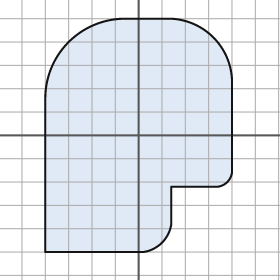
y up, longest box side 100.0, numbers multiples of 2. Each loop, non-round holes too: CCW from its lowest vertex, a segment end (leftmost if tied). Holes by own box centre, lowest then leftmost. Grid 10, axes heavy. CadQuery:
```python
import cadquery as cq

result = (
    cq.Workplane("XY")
    .moveTo(-40.0, -50.0)
    .lineTo(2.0, -50.0)
    .threePointArc((10.0, -46.0), (14.0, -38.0))
    .lineTo(14.0, -22.0)
    .lineTo(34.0, -22.0)
    .threePointArc((38.0, -20.0), (40.0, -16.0))
    .lineTo(40.0, 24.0)
    .threePointArc((32.0, 42.0), (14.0, 50.0))
    .lineTo(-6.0, 50.0)
    .threePointArc((-30.0, 40.0), (-40.0, 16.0))
    .close()
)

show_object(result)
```